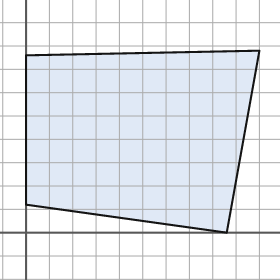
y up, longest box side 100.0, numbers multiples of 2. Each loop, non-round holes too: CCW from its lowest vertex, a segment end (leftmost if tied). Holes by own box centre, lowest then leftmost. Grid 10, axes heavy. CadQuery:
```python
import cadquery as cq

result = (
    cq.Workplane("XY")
    .moveTo(86.0, 0.0)
    .lineTo(100.0, 78.0)
    .lineTo(0.0, 76.0)
    .lineTo(0.0, 12.0)
    .close()
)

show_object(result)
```